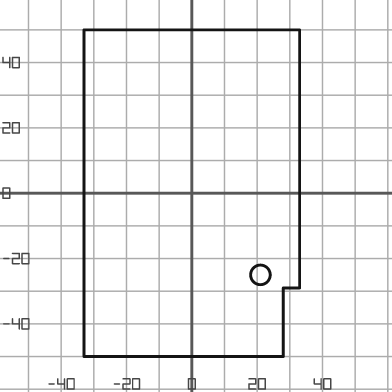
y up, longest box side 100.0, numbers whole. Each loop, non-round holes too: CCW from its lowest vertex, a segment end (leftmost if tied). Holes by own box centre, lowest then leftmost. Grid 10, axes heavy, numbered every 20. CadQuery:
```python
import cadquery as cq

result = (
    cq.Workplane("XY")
    .moveTo(-33.0, -50.0)
    .lineTo(28.0, -50.0)
    .lineTo(28.0, -29.0)
    .lineTo(33.0, -29.0)
    .lineTo(33.0, 50.0)
    .lineTo(-33.0, 50.0)
    .close()
    .moveTo(21.0, -25.0)
    .circle(3.0)
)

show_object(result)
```